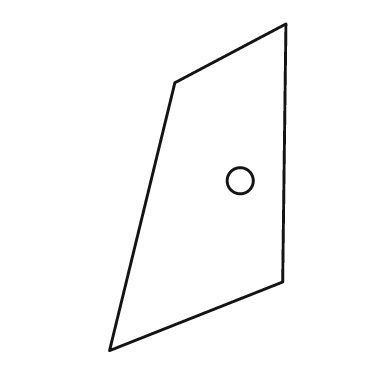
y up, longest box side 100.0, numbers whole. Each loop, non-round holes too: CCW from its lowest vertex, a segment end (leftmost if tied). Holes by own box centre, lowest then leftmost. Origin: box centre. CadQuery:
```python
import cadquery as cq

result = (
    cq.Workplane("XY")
    .moveTo(-27.0, -50.0)
    .lineTo(26.0, -29.0)
    .lineTo(27.0, 50.0)
    .lineTo(-7.0, 32.0)
    .close()
    .moveTo(13.0, 2.0)
    .circle(4.0)
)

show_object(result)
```